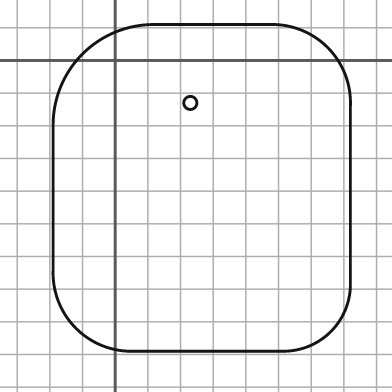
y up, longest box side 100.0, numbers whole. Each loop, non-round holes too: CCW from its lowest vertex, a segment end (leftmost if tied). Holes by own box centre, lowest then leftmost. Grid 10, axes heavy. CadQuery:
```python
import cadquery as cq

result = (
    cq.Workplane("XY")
    .moveTo(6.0, -89.0)
    .lineTo(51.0, -89.0)
    .threePointArc((66.0, -83.0), (72.0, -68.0))
    .lineTo(72.0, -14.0)
    .threePointArc((65.0, 4.0), (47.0, 11.0))
    .lineTo(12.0, 11.0)
    .threePointArc((-10.0, 2.0), (-19.0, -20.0))
    .lineTo(-19.0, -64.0)
    .threePointArc((-12.0, -82.0), (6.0, -89.0))
    .close()
    .moveTo(23.0, -13.0)
    .circle(2.0)
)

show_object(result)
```